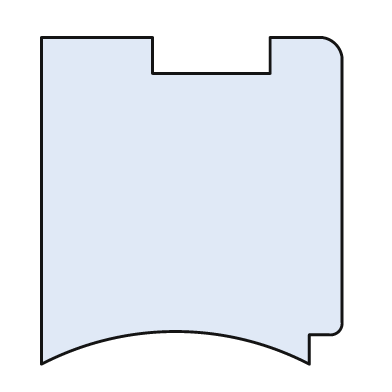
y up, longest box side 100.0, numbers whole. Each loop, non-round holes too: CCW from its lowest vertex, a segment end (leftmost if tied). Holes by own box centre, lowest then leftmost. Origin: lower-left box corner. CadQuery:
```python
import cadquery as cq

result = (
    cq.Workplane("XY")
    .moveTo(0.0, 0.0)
    .threePointArc((41.0, 10.0), (82.0, 0.0))
    .lineTo(82.0, 9.0)
    .lineTo(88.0, 9.0)
    .threePointArc((91.0, 10.0), (92.0, 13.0))
    .lineTo(92.0, 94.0)
    .threePointArc((90.0, 98.0), (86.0, 100.0))
    .lineTo(70.0, 100.0)
    .lineTo(70.0, 89.0)
    .lineTo(34.0, 89.0)
    .lineTo(34.0, 100.0)
    .lineTo(0.0, 100.0)
    .close()
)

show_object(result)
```